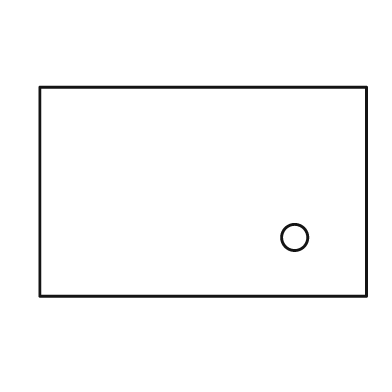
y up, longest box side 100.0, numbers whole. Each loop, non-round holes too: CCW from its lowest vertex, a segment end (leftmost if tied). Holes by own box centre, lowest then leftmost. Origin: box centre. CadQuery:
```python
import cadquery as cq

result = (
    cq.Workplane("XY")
    .moveTo(-50.0, -32.0)
    .lineTo(50.0, -32.0)
    .lineTo(50.0, 32.0)
    .lineTo(-50.0, 32.0)
    .close()
    .moveTo(28.0, -14.0)
    .circle(4.0)
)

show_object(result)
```